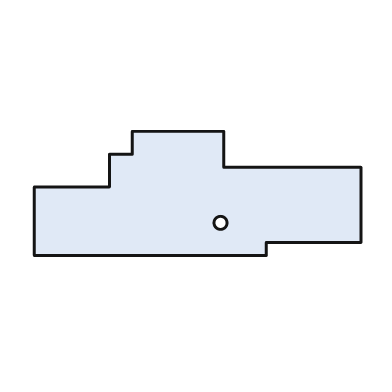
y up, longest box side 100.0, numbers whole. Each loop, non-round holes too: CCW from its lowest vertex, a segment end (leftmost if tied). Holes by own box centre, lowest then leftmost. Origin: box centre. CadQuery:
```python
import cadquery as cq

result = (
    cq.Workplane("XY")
    .moveTo(-50.0, -19.0)
    .lineTo(21.0, -19.0)
    .lineTo(21.0, -15.0)
    .lineTo(50.0, -15.0)
    .lineTo(50.0, 8.0)
    .lineTo(8.0, 8.0)
    .lineTo(8.0, 19.0)
    .lineTo(-20.0, 19.0)
    .lineTo(-20.0, 12.0)
    .lineTo(-27.0, 12.0)
    .lineTo(-27.0, 2.0)
    .lineTo(-50.0, 2.0)
    .close()
    .moveTo(7.0, -9.0)
    .circle(2.0)
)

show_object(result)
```